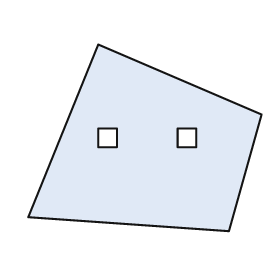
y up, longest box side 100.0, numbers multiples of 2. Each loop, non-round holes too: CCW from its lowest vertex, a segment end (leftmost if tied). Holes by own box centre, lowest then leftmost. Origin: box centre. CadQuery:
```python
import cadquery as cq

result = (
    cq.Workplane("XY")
    .moveTo(36.0, -40.0)
    .lineTo(50.0, 10.0)
    .lineTo(-20.0, 40.0)
    .lineTo(-50.0, -34.0)
    .close()
    .moveTo(-20.0, -4.0)
    .lineTo(-12.0, -4.0)
    .lineTo(-12.0, 4.0)
    .lineTo(-20.0, 4.0)
    .close()
    .moveTo(14.0, -4.0)
    .lineTo(22.0, -4.0)
    .lineTo(22.0, 4.0)
    .lineTo(14.0, 4.0)
    .close()
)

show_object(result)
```